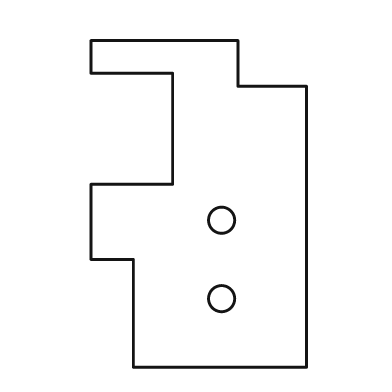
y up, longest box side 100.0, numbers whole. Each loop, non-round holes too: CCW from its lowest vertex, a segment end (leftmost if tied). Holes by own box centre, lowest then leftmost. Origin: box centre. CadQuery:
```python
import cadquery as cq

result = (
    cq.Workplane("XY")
    .moveTo(-20.0, -50.0)
    .lineTo(33.0, -50.0)
    .lineTo(33.0, 36.0)
    .lineTo(12.0, 36.0)
    .lineTo(12.0, 50.0)
    .lineTo(-33.0, 50.0)
    .lineTo(-33.0, 40.0)
    .lineTo(-8.0, 40.0)
    .lineTo(-8.0, 6.0)
    .lineTo(-33.0, 6.0)
    .lineTo(-33.0, -17.0)
    .lineTo(-20.0, -17.0)
    .close()
    .moveTo(7.0, -29.0)
    .circle(4.0)
    .moveTo(7.0, -5.0)
    .circle(4.0)
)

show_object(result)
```